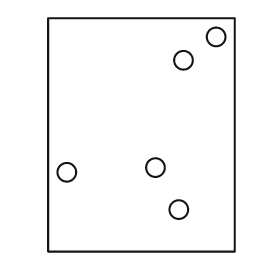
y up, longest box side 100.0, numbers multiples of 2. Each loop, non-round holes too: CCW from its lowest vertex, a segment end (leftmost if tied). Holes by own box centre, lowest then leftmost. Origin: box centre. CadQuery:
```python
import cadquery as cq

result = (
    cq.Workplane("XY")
    .moveTo(-40.0, -50.0)
    .lineTo(40.0, -50.0)
    .lineTo(40.0, 50.0)
    .lineTo(-40.0, 50.0)
    .close()
    .moveTo(16.0, -32.0)
    .circle(4.0)
    .moveTo(-32.0, -16.0)
    .circle(4.0)
    .moveTo(6.0, -14.0)
    .circle(4.0)
    .moveTo(18.0, 32.0)
    .circle(4.0)
    .moveTo(32.0, 42.0)
    .circle(4.0)
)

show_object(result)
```